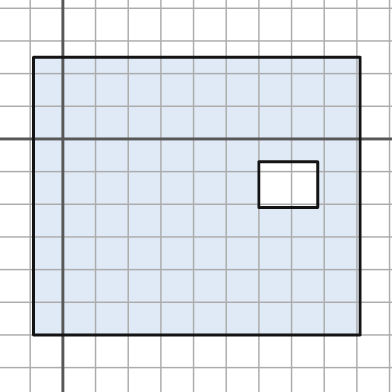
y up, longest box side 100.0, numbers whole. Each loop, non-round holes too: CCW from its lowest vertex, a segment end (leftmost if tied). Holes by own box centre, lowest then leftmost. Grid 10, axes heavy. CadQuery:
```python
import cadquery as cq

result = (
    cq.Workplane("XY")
    .moveTo(-9.0, -60.0)
    .lineTo(91.0, -60.0)
    .lineTo(91.0, 25.0)
    .lineTo(-9.0, 25.0)
    .close()
    .moveTo(60.0, -21.0)
    .lineTo(78.0, -21.0)
    .lineTo(78.0, -7.0)
    .lineTo(60.0, -7.0)
    .close()
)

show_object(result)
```